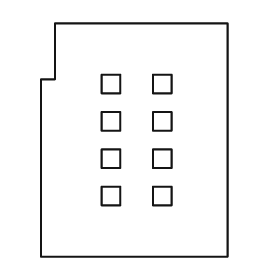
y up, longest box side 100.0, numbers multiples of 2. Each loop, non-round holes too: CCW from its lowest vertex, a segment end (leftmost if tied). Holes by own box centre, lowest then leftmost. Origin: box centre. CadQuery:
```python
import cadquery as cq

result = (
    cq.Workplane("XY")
    .moveTo(-40.0, -50.0)
    .lineTo(40.0, -50.0)
    .lineTo(40.0, 50.0)
    .lineTo(-34.0, 50.0)
    .lineTo(-34.0, 26.0)
    .lineTo(-40.0, 26.0)
    .close()
    .moveTo(-14.0, -28.0)
    .lineTo(-6.0, -28.0)
    .lineTo(-6.0, -20.0)
    .lineTo(-14.0, -20.0)
    .close()
    .moveTo(8.0, -28.0)
    .lineTo(16.0, -28.0)
    .lineTo(16.0, -20.0)
    .lineTo(8.0, -20.0)
    .close()
    .moveTo(-14.0, -12.0)
    .lineTo(-6.0, -12.0)
    .lineTo(-6.0, -4.0)
    .lineTo(-14.0, -4.0)
    .close()
    .moveTo(8.0, -12.0)
    .lineTo(16.0, -12.0)
    .lineTo(16.0, -4.0)
    .lineTo(8.0, -4.0)
    .close()
    .moveTo(-14.0, 4.0)
    .lineTo(-6.0, 4.0)
    .lineTo(-6.0, 12.0)
    .lineTo(-14.0, 12.0)
    .close()
    .moveTo(8.0, 4.0)
    .lineTo(16.0, 4.0)
    .lineTo(16.0, 12.0)
    .lineTo(8.0, 12.0)
    .close()
    .moveTo(-14.0, 20.0)
    .lineTo(-6.0, 20.0)
    .lineTo(-6.0, 28.0)
    .lineTo(-14.0, 28.0)
    .close()
    .moveTo(8.0, 20.0)
    .lineTo(16.0, 20.0)
    .lineTo(16.0, 28.0)
    .lineTo(8.0, 28.0)
    .close()
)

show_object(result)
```